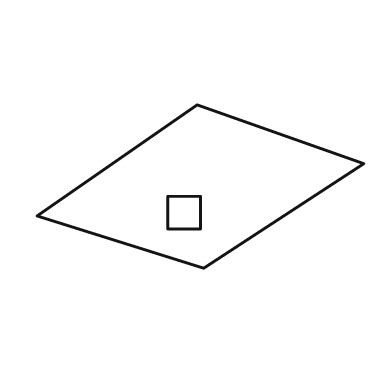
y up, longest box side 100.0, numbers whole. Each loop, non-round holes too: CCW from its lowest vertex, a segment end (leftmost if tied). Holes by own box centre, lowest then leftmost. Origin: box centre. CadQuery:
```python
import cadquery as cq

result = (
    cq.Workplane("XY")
    .moveTo(1.0, -25.0)
    .lineTo(50.0, 7.0)
    .lineTo(-1.0, 25.0)
    .lineTo(-50.0, -9.0)
    .close()
    .moveTo(-10.0, -13.0)
    .lineTo(0.0, -13.0)
    .lineTo(0.0, -3.0)
    .lineTo(-10.0, -3.0)
    .close()
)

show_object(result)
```